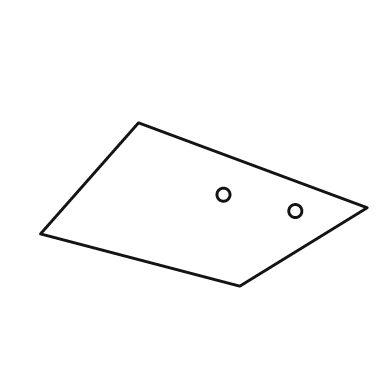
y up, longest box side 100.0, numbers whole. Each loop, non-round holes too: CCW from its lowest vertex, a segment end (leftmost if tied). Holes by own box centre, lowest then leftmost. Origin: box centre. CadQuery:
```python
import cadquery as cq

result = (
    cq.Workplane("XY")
    .moveTo(11.0, -25.0)
    .lineTo(50.0, -1.0)
    .lineTo(-20.0, 25.0)
    .lineTo(-50.0, -9.0)
    .close()
    .moveTo(28.0, -2.0)
    .circle(2.0)
    .moveTo(6.0, 3.0)
    .circle(2.0)
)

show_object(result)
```